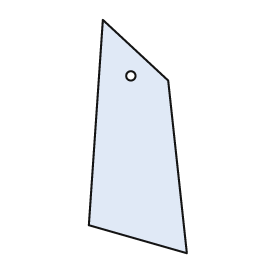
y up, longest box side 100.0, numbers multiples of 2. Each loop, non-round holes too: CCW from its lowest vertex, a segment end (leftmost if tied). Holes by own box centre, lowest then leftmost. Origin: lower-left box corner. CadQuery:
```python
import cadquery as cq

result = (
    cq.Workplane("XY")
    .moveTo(42.0, 0.0)
    .lineTo(34.0, 74.0)
    .lineTo(6.0, 100.0)
    .lineTo(0.0, 12.0)
    .close()
    .moveTo(18.0, 76.0)
    .circle(2.0)
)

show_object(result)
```